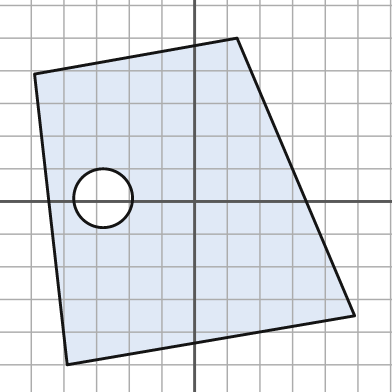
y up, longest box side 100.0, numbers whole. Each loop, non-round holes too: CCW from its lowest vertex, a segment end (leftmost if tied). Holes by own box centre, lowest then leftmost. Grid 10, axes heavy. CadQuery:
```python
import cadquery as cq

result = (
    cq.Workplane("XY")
    .moveTo(-39.0, -50.0)
    .lineTo(49.0, -35.0)
    .lineTo(13.0, 50.0)
    .lineTo(-49.0, 39.0)
    .close()
    .moveTo(-28.0, 1.0)
    .circle(9.0)
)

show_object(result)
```